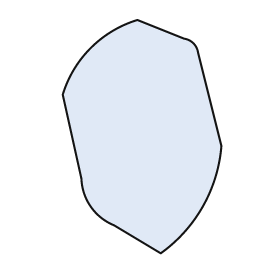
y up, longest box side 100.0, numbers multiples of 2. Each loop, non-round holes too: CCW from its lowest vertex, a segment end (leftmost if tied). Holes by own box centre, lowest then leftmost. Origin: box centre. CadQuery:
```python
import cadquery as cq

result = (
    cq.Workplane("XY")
    .moveTo(8.0, -50.0)
    .threePointArc((26.0, -30.0), (34.0, -4.0))
    .lineTo(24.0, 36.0)
    .threePointArc((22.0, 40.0), (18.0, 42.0))
    .lineTo(-2.0, 50.0)
    .threePointArc((-22.0, 38.0), (-34.0, 18.0))
    .lineTo(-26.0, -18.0)
    .threePointArc((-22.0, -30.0), (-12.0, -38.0))
    .close()
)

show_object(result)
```